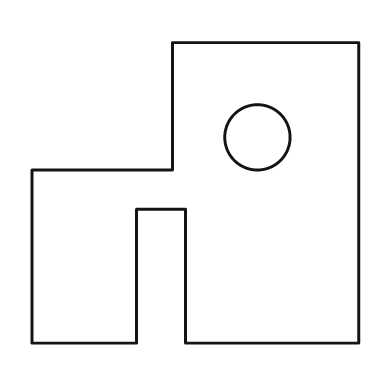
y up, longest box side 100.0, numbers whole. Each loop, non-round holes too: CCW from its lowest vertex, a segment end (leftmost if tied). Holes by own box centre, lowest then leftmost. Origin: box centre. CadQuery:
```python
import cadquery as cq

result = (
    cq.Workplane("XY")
    .moveTo(-50.0, -46.0)
    .lineTo(-18.0, -46.0)
    .lineTo(-18.0, -5.0)
    .lineTo(-3.0, -5.0)
    .lineTo(-3.0, -46.0)
    .lineTo(50.0, -46.0)
    .lineTo(50.0, 46.0)
    .lineTo(-7.0, 46.0)
    .lineTo(-7.0, 7.0)
    .lineTo(-50.0, 7.0)
    .close()
    .moveTo(19.0, 17.0)
    .circle(10.0)
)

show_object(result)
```